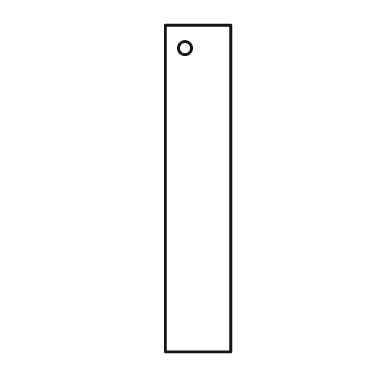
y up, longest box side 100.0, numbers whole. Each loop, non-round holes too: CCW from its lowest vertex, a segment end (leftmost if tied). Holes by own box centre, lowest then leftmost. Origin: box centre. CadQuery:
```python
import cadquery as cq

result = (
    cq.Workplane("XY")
    .moveTo(-10.0, -50.0)
    .lineTo(10.0, -50.0)
    .lineTo(10.0, 50.0)
    .lineTo(-10.0, 50.0)
    .close()
    .moveTo(-4.0, 43.0)
    .circle(2.0)
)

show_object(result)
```